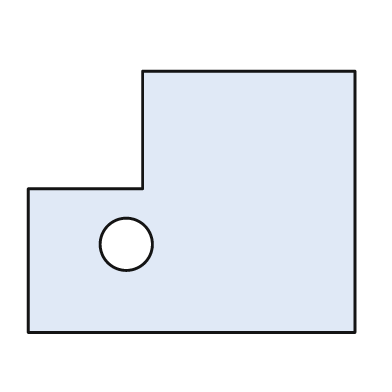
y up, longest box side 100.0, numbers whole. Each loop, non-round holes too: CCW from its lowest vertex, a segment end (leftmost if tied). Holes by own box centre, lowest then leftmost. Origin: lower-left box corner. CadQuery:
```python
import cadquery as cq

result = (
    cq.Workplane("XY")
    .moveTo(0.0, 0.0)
    .lineTo(100.0, 0.0)
    .lineTo(100.0, 80.0)
    .lineTo(35.0, 80.0)
    .lineTo(35.0, 44.0)
    .lineTo(0.0, 44.0)
    .close()
    .moveTo(30.0, 27.0)
    .circle(8.0)
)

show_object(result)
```